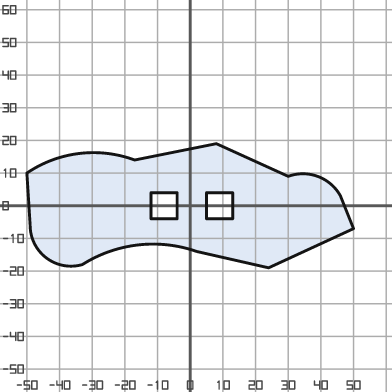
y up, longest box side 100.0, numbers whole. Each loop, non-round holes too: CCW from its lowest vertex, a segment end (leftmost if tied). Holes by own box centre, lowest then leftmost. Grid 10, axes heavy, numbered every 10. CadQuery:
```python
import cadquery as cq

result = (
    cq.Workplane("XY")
    .moveTo(24.0, -19.0)
    .lineTo(50.0, -7.0)
    .lineTo(46.0, 3.0)
    .threePointArc((39.0, 9.0), (30.0, 9.0))
    .lineTo(8.0, 19.0)
    .lineTo(-17.0, 14.0)
    .threePointArc((-34.0, 16.0), (-50.0, 10.0))
    .lineTo(-49.0, -6.0)
    .threePointArc((-44.0, -16.0), (-33.0, -18.0))
    .threePointArc((-16.0, -12.0), (2.0, -14.0))
    .close()
    .moveTo(-12.0, -4.0)
    .lineTo(-4.0, -4.0)
    .lineTo(-4.0, 4.0)
    .lineTo(-12.0, 4.0)
    .close()
    .moveTo(5.0, -4.0)
    .lineTo(13.0, -4.0)
    .lineTo(13.0, 4.0)
    .lineTo(5.0, 4.0)
    .close()
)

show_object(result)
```